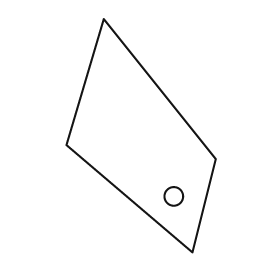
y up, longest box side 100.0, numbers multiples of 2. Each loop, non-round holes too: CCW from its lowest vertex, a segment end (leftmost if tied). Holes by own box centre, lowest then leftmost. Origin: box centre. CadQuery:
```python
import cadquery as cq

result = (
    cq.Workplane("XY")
    .moveTo(22.0, -50.0)
    .lineTo(32.0, -10.0)
    .lineTo(-16.0, 50.0)
    .lineTo(-32.0, -4.0)
    .close()
    .moveTo(14.0, -26.0)
    .circle(4.0)
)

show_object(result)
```